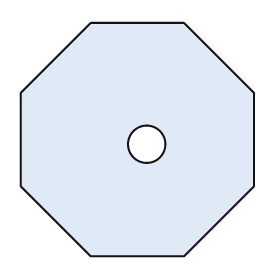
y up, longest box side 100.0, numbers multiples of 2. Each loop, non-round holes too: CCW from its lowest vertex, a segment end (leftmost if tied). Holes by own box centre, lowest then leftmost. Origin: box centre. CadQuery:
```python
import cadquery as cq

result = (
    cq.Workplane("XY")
    .moveTo(-20.0, -50.0)
    .lineTo(20.0, -50.0)
    .lineTo(50.0, -20.0)
    .lineTo(50.0, 20.0)
    .lineTo(20.0, 50.0)
    .lineTo(-20.0, 50.0)
    .lineTo(-50.0, 20.0)
    .lineTo(-50.0, -20.0)
    .close()
    .moveTo(4.0, -2.0)
    .circle(8.0)
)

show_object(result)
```